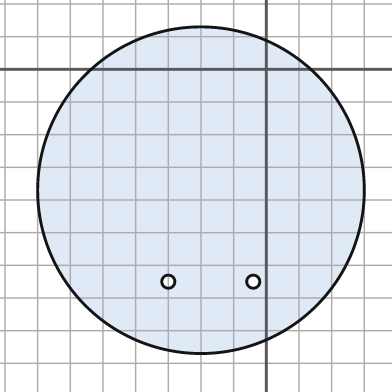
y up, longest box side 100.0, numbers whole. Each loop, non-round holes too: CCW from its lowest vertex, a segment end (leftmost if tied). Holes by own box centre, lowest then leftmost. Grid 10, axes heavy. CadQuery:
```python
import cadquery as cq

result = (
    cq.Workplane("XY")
    .moveTo(-20.0, -37.0)
    .circle(50.0)
    .moveTo(-30.0, -65.0)
    .circle(2.0)
    .moveTo(-4.0, -65.0)
    .circle(2.0)
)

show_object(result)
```